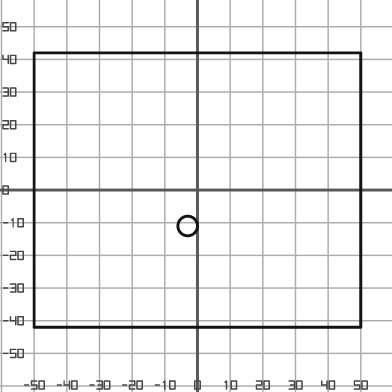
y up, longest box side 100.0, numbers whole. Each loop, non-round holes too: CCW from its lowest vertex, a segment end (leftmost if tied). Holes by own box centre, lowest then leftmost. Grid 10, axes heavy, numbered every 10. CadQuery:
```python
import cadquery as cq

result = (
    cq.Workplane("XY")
    .moveTo(-50.0, -42.0)
    .lineTo(50.0, -42.0)
    .lineTo(50.0, 42.0)
    .lineTo(-50.0, 42.0)
    .close()
    .moveTo(-3.0, -11.0)
    .circle(3.0)
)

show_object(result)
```